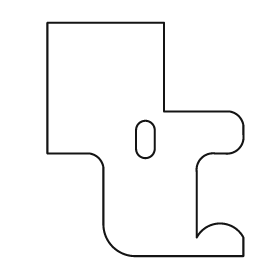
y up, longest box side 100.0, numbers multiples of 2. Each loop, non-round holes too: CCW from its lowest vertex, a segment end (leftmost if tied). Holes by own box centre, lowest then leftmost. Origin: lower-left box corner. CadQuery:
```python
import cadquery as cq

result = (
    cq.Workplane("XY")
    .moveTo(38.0, 0.0)
    .lineTo(84.0, 0.0)
    .lineTo(84.0, 8.0)
    .threePointArc((74.0, 14.0), (64.0, 8.0))
    .lineTo(64.0, 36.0)
    .threePointArc((66.0, 42.0), (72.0, 44.0))
    .lineTo(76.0, 44.0)
    .threePointArc((82.0, 46.0), (84.0, 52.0))
    .lineTo(84.0, 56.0)
    .threePointArc((82.0, 60.0), (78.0, 62.0))
    .lineTo(50.0, 62.0)
    .lineTo(50.0, 100.0)
    .lineTo(0.0, 100.0)
    .lineTo(0.0, 44.0)
    .lineTo(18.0, 44.0)
    .threePointArc((22.0, 42.0), (24.0, 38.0))
    .lineTo(24.0, 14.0)
    .threePointArc((28.0, 4.0), (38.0, 0.0))
    .close()
    .moveTo(38.0, 46.0)
    .threePointArc((42.0, 42.0), (46.0, 46.0))
    .lineTo(46.0, 54.0)
    .threePointArc((42.0, 58.0), (38.0, 54.0))
    .close()
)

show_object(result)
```